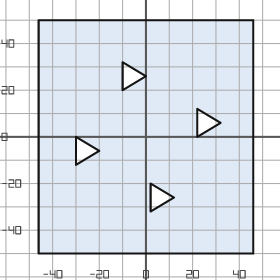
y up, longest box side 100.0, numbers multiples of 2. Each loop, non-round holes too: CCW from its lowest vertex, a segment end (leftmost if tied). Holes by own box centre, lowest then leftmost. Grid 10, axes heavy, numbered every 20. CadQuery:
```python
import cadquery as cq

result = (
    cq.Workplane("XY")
    .moveTo(-46.0, -50.0)
    .lineTo(46.0, -50.0)
    .lineTo(46.0, 50.0)
    .lineTo(-46.0, 50.0)
    .close()
    .moveTo(2.0, -32.0)
    .lineTo(12.0, -26.0)
    .lineTo(2.0, -20.0)
    .close()
    .moveTo(-30.0, -12.0)
    .lineTo(-20.0, -6.0)
    .lineTo(-30.0, 0.0)
    .close()
    .moveTo(22.0, 0.0)
    .lineTo(32.0, 6.0)
    .lineTo(22.0, 12.0)
    .close()
    .moveTo(-10.0, 20.0)
    .lineTo(0.0, 26.0)
    .lineTo(-10.0, 32.0)
    .close()
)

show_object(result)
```